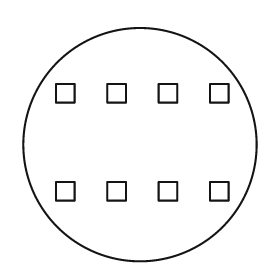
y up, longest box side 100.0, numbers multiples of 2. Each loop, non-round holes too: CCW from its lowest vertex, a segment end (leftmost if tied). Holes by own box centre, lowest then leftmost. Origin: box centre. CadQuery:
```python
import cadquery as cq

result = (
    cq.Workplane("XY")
    .moveTo(0.0, 0.0)
    .circle(50.0)
    .moveTo(-36.0, -24.0)
    .lineTo(-28.0, -24.0)
    .lineTo(-28.0, -16.0)
    .lineTo(-36.0, -16.0)
    .close()
    .moveTo(-14.0, -24.0)
    .lineTo(-6.0, -24.0)
    .lineTo(-6.0, -16.0)
    .lineTo(-14.0, -16.0)
    .close()
    .moveTo(8.0, -24.0)
    .lineTo(16.0, -24.0)
    .lineTo(16.0, -16.0)
    .lineTo(8.0, -16.0)
    .close()
    .moveTo(30.0, -24.0)
    .lineTo(38.0, -24.0)
    .lineTo(38.0, -16.0)
    .lineTo(30.0, -16.0)
    .close()
    .moveTo(-36.0, 18.0)
    .lineTo(-28.0, 18.0)
    .lineTo(-28.0, 26.0)
    .lineTo(-36.0, 26.0)
    .close()
    .moveTo(-14.0, 18.0)
    .lineTo(-6.0, 18.0)
    .lineTo(-6.0, 26.0)
    .lineTo(-14.0, 26.0)
    .close()
    .moveTo(8.0, 18.0)
    .lineTo(16.0, 18.0)
    .lineTo(16.0, 26.0)
    .lineTo(8.0, 26.0)
    .close()
    .moveTo(30.0, 18.0)
    .lineTo(38.0, 18.0)
    .lineTo(38.0, 26.0)
    .lineTo(30.0, 26.0)
    .close()
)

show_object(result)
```